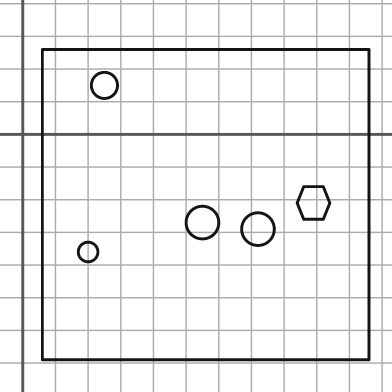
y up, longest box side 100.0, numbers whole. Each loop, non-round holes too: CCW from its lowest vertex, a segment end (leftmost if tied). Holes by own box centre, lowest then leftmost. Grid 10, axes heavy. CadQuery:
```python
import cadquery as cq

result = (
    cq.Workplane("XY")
    .moveTo(6.0, -69.0)
    .lineTo(106.0, -69.0)
    .lineTo(106.0, 26.0)
    .lineTo(6.0, 26.0)
    .close()
    .moveTo(20.0, -36.0)
    .circle(3.0)
    .moveTo(72.0, -29.0)
    .circle(5.0)
    .moveTo(55.0, -27.0)
    .circle(5.0)
    .moveTo(86.0, -26.0)
    .lineTo(92.0, -26.0)
    .lineTo(94.0, -21.0)
    .lineTo(92.0, -16.0)
    .lineTo(86.0, -16.0)
    .lineTo(84.0, -21.0)
    .close()
    .moveTo(25.0, 15.0)
    .circle(4.0)
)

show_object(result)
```